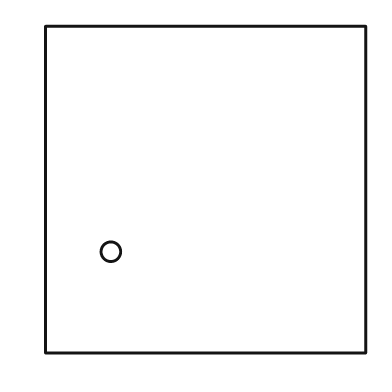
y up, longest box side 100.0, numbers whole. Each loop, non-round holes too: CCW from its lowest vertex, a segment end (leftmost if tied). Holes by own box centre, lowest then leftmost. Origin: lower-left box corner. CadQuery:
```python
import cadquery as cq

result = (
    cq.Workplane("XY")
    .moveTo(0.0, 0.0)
    .lineTo(98.0, 0.0)
    .lineTo(98.0, 100.0)
    .lineTo(0.0, 100.0)
    .close()
    .moveTo(20.0, 31.0)
    .circle(3.0)
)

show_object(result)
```